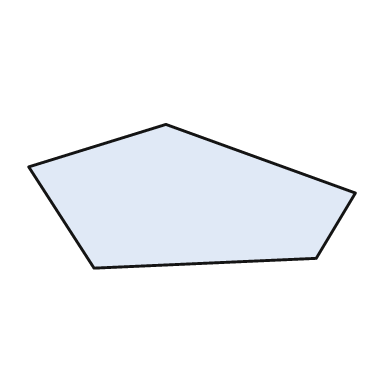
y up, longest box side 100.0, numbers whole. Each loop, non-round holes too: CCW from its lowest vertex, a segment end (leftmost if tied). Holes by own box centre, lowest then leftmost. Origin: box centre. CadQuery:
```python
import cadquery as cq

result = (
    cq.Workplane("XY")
    .moveTo(-30.0, -22.0)
    .lineTo(38.0, -19.0)
    .lineTo(50.0, 1.0)
    .lineTo(-8.0, 22.0)
    .lineTo(-50.0, 9.0)
    .close()
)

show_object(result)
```